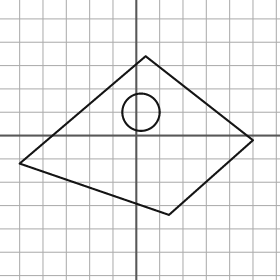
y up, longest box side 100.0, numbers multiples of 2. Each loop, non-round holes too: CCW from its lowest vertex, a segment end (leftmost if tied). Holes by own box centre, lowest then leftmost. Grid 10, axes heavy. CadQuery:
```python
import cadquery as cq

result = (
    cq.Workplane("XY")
    .moveTo(14.0, -34.0)
    .lineTo(50.0, -2.0)
    .lineTo(4.0, 34.0)
    .lineTo(-50.0, -12.0)
    .close()
    .moveTo(2.0, 10.0)
    .circle(8.0)
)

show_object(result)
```